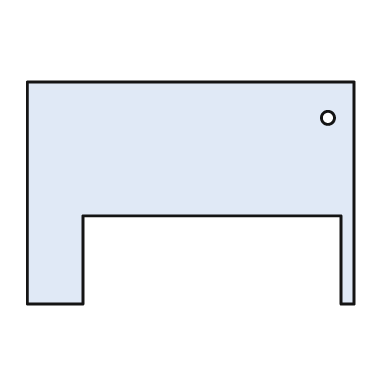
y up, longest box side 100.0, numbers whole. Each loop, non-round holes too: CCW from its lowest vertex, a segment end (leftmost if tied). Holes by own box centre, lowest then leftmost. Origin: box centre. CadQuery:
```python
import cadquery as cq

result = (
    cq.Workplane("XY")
    .moveTo(-50.0, -34.0)
    .lineTo(-33.0, -34.0)
    .lineTo(-33.0, -7.0)
    .lineTo(46.0, -7.0)
    .lineTo(46.0, -34.0)
    .lineTo(50.0, -34.0)
    .lineTo(50.0, 34.0)
    .lineTo(-50.0, 34.0)
    .close()
    .moveTo(42.0, 23.0)
    .circle(2.0)
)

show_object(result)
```